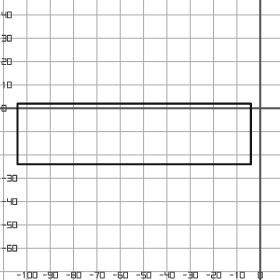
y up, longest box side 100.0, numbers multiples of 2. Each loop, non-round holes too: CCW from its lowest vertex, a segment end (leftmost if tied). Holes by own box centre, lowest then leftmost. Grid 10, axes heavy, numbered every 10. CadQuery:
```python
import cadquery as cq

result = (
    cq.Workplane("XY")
    .moveTo(-104.0, -24.0)
    .lineTo(-4.0, -24.0)
    .lineTo(-4.0, 2.0)
    .lineTo(-104.0, 2.0)
    .close()
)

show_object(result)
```